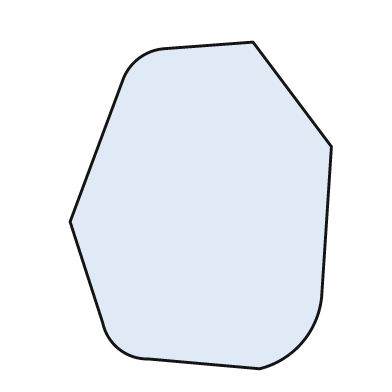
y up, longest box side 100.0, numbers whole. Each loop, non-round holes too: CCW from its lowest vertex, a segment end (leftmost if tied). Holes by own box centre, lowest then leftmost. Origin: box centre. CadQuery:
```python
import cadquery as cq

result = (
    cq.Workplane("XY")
    .moveTo(18.0, -50.0)
    .threePointArc((31.0, -42.0), (37.0, -28.0))
    .lineTo(40.0, 18.0)
    .lineTo(16.0, 50.0)
    .lineTo(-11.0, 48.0)
    .threePointArc((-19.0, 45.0), (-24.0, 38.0))
    .lineTo(-40.0, -5.0)
    .lineTo(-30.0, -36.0)
    .threePointArc((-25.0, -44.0), (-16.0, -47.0))
    .close()
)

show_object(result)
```